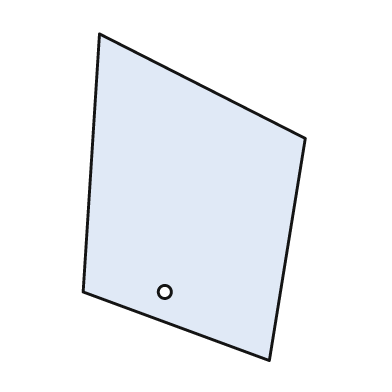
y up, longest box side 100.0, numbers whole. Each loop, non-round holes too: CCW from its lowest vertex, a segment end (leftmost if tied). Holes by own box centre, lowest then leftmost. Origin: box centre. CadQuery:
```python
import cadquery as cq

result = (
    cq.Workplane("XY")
    .moveTo(23.0, -50.0)
    .lineTo(34.0, 18.0)
    .lineTo(-29.0, 50.0)
    .lineTo(-34.0, -29.0)
    .close()
    .moveTo(-9.0, -29.0)
    .circle(2.0)
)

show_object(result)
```